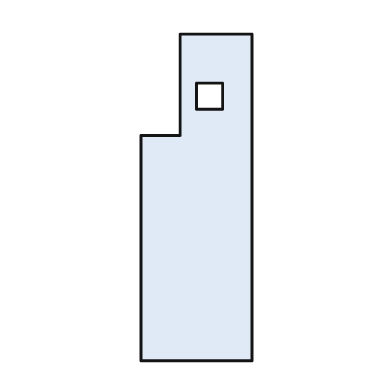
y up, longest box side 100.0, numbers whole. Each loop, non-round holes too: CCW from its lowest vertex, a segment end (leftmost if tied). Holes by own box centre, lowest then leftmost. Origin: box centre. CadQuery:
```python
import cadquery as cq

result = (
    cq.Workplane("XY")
    .moveTo(-17.0, -50.0)
    .lineTo(17.0, -50.0)
    .lineTo(17.0, 50.0)
    .lineTo(-5.0, 50.0)
    .lineTo(-5.0, 19.0)
    .lineTo(-17.0, 19.0)
    .close()
    .moveTo(0.0, 27.0)
    .lineTo(8.0, 27.0)
    .lineTo(8.0, 35.0)
    .lineTo(0.0, 35.0)
    .close()
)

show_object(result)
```